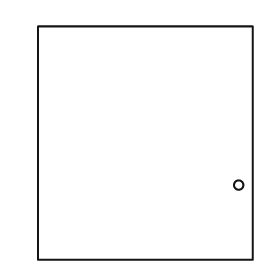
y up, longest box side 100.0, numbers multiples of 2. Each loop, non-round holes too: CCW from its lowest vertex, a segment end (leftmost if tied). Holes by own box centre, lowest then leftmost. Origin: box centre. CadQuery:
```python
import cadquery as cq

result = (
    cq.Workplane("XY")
    .moveTo(-46.0, -50.0)
    .lineTo(46.0, -50.0)
    .lineTo(46.0, 50.0)
    .lineTo(-46.0, 50.0)
    .close()
    .moveTo(40.0, -18.0)
    .circle(2.0)
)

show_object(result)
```